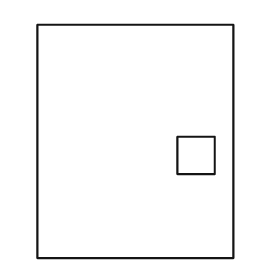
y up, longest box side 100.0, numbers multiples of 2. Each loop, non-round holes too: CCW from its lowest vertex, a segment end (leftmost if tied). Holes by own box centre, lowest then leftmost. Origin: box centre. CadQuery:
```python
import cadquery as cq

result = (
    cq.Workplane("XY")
    .moveTo(-42.0, -50.0)
    .lineTo(42.0, -50.0)
    .lineTo(42.0, 50.0)
    .lineTo(-42.0, 50.0)
    .close()
    .moveTo(18.0, -14.0)
    .lineTo(34.0, -14.0)
    .lineTo(34.0, 2.0)
    .lineTo(18.0, 2.0)
    .close()
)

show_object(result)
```